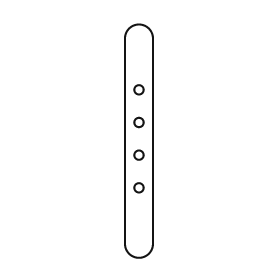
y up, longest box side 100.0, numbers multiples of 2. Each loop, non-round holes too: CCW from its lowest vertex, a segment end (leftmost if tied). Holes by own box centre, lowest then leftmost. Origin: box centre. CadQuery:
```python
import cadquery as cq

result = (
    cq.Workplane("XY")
    .moveTo(-6.0, -44.0)
    .threePointArc((0.0, -50.0), (6.0, -44.0))
    .lineTo(6.0, 44.0)
    .threePointArc((0.0, 50.0), (-6.0, 44.0))
    .close()
    .moveTo(0.0, -20.0)
    .circle(2.0)
    .moveTo(0.0, -6.0)
    .circle(2.0)
    .moveTo(0.0, 8.0)
    .circle(2.0)
    .moveTo(0.0, 22.0)
    .circle(2.0)
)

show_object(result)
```